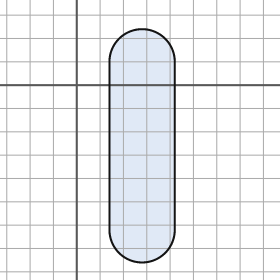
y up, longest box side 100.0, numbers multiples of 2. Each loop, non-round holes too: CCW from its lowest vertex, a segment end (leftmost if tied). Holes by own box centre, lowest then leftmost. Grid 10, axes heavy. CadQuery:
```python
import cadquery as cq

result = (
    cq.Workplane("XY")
    .moveTo(14.0, -62.0)
    .threePointArc((28.0, -76.0), (42.0, -62.0))
    .lineTo(42.0, 10.0)
    .threePointArc((28.0, 24.0), (14.0, 10.0))
    .close()
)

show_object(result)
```